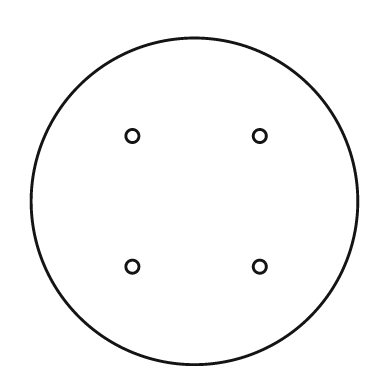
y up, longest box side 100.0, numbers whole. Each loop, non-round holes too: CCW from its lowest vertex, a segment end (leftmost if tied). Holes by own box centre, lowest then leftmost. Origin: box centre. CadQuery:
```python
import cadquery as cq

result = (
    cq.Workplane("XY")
    .moveTo(0.0, 0.0)
    .circle(50.0)
    .moveTo(-19.0, -20.0)
    .circle(2.0)
    .moveTo(20.0, -20.0)
    .circle(2.0)
    .moveTo(-19.0, 20.0)
    .circle(2.0)
    .moveTo(20.0, 20.0)
    .circle(2.0)
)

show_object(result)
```